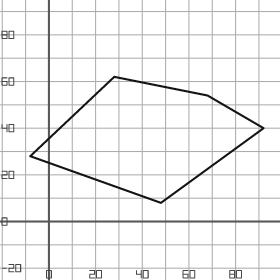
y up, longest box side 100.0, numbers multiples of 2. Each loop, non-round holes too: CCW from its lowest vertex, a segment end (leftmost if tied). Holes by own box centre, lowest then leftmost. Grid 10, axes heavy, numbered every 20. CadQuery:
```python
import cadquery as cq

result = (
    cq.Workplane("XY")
    .moveTo(48.0, 8.0)
    .lineTo(92.0, 40.0)
    .lineTo(68.0, 54.0)
    .lineTo(28.0, 62.0)
    .lineTo(-8.0, 28.0)
    .close()
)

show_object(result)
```